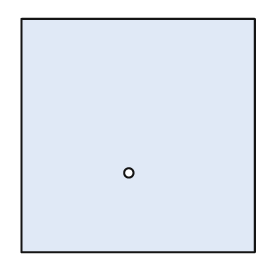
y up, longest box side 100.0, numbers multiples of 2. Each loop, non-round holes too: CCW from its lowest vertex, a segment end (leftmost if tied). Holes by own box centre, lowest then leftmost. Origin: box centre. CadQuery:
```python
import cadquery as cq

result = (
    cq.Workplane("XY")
    .moveTo(-50.0, -50.0)
    .lineTo(50.0, -50.0)
    .lineTo(50.0, 50.0)
    .lineTo(-50.0, 50.0)
    .close()
    .moveTo(-4.0, -16.0)
    .circle(2.0)
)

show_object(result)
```